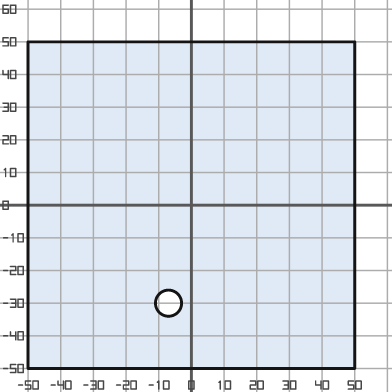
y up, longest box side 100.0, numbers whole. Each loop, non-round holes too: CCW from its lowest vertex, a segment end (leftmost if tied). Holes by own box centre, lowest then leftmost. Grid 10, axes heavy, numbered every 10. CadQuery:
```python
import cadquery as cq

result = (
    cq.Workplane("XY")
    .moveTo(-50.0, -50.0)
    .lineTo(50.0, -50.0)
    .lineTo(50.0, 50.0)
    .lineTo(-50.0, 50.0)
    .close()
    .moveTo(-7.0, -30.0)
    .circle(4.0)
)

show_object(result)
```